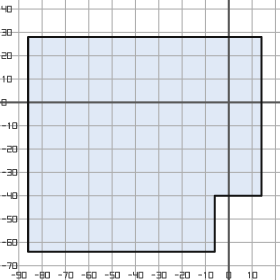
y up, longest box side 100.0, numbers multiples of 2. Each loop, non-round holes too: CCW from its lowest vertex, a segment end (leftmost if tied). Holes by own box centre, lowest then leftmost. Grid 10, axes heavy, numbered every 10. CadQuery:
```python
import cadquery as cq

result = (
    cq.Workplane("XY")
    .moveTo(-86.0, -64.0)
    .lineTo(-6.0, -64.0)
    .lineTo(-6.0, -40.0)
    .lineTo(14.0, -40.0)
    .lineTo(14.0, 28.0)
    .lineTo(-86.0, 28.0)
    .close()
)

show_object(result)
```